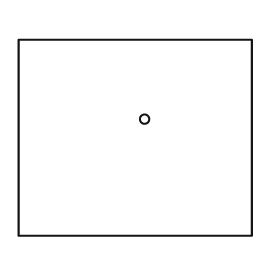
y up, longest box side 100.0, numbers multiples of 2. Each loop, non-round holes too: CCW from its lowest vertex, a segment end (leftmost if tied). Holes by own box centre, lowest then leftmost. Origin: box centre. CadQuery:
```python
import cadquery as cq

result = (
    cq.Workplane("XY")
    .moveTo(-50.0, -42.0)
    .lineTo(50.0, -42.0)
    .lineTo(50.0, 42.0)
    .lineTo(-50.0, 42.0)
    .close()
    .moveTo(4.0, 8.0)
    .circle(2.0)
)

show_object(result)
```